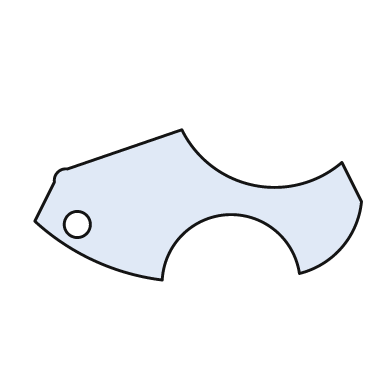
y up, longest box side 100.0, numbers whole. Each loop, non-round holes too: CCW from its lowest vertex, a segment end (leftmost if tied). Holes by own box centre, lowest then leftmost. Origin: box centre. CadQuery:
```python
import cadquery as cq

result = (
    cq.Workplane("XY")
    .moveTo(-11.0, -23.0)
    .threePointArc((9.0, -3.0), (31.0, -21.0))
    .threePointArc((44.0, -13.0), (50.0, 1.0))
    .lineTo(44.0, 13.0)
    .threePointArc((17.0, 6.0), (-5.0, 23.0))
    .lineTo(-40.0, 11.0)
    .threePointArc((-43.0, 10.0), (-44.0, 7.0))
    .lineTo(-50.0, -5.0)
    .threePointArc((-32.0, -17.0), (-11.0, -23.0))
    .close()
    .moveTo(-37.0, -6.0)
    .circle(4.0)
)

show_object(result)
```